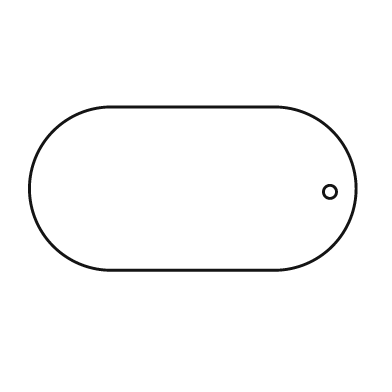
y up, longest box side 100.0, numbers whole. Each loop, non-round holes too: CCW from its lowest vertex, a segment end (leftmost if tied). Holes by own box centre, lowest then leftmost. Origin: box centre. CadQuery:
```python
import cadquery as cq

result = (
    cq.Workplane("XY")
    .moveTo(-25.0, -25.0)
    .lineTo(25.0, -25.0)
    .threePointArc((50.0, 0.0), (25.0, 25.0))
    .lineTo(-25.0, 25.0)
    .threePointArc((-50.0, 0.0), (-25.0, -25.0))
    .close()
    .moveTo(42.0, -1.0)
    .circle(2.0)
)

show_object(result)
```